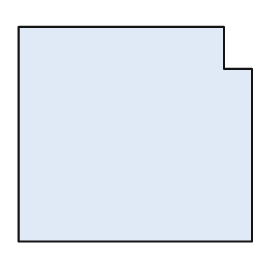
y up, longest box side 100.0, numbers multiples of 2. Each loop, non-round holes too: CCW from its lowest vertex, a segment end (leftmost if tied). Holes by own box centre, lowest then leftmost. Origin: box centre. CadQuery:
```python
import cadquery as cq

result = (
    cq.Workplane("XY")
    .moveTo(-50.0, -46.0)
    .lineTo(50.0, -46.0)
    .lineTo(50.0, 28.0)
    .lineTo(38.0, 28.0)
    .lineTo(38.0, 46.0)
    .lineTo(-50.0, 46.0)
    .close()
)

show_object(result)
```